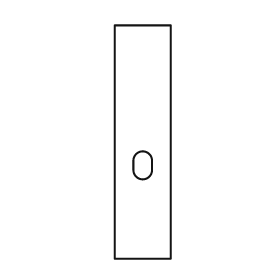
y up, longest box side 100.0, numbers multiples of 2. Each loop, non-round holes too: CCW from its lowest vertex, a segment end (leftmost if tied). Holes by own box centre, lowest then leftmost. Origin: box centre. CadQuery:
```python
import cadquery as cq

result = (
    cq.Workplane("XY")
    .moveTo(-12.0, -50.0)
    .lineTo(12.0, -50.0)
    .lineTo(12.0, 50.0)
    .lineTo(-12.0, 50.0)
    .close()
    .moveTo(-4.0, -12.0)
    .threePointArc((0.0, -16.0), (4.0, -12.0))
    .lineTo(4.0, -8.0)
    .threePointArc((0.0, -4.0), (-4.0, -8.0))
    .close()
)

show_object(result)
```